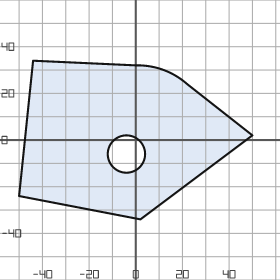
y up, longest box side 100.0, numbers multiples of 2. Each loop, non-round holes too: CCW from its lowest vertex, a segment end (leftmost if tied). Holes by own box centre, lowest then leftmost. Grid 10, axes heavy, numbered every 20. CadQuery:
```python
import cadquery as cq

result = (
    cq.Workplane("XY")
    .moveTo(2.0, -34.0)
    .lineTo(50.0, 2.0)
    .lineTo(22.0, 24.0)
    .threePointArc((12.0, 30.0), (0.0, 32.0))
    .lineTo(-44.0, 34.0)
    .lineTo(-50.0, -24.0)
    .close()
    .moveTo(-4.0, -6.0)
    .circle(8.0)
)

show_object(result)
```